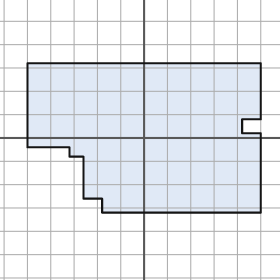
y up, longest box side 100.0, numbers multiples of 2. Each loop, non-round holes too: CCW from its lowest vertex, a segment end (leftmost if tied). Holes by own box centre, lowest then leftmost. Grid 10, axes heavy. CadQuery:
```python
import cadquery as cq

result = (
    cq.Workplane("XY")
    .moveTo(-18.0, -32.0)
    .lineTo(50.0, -32.0)
    .lineTo(50.0, 2.0)
    .lineTo(42.0, 2.0)
    .lineTo(42.0, 8.0)
    .lineTo(50.0, 8.0)
    .lineTo(50.0, 32.0)
    .lineTo(-50.0, 32.0)
    .lineTo(-50.0, -4.0)
    .lineTo(-32.0, -4.0)
    .lineTo(-32.0, -8.0)
    .lineTo(-26.0, -8.0)
    .lineTo(-26.0, -26.0)
    .lineTo(-18.0, -26.0)
    .close()
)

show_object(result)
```